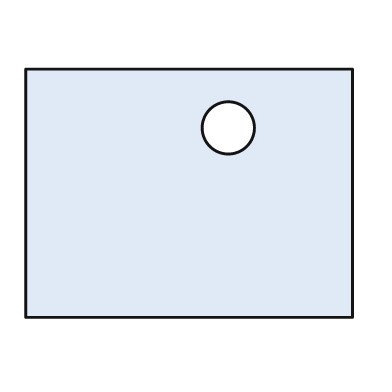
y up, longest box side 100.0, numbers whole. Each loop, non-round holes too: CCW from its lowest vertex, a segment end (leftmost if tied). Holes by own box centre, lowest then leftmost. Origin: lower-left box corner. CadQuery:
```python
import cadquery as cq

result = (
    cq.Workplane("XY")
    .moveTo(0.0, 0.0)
    .lineTo(100.0, 0.0)
    .lineTo(100.0, 76.0)
    .lineTo(0.0, 76.0)
    .close()
    .moveTo(62.0, 58.0)
    .circle(8.0)
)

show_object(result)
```